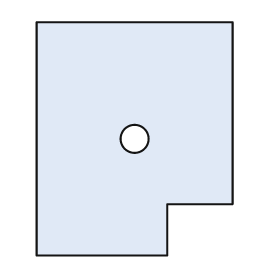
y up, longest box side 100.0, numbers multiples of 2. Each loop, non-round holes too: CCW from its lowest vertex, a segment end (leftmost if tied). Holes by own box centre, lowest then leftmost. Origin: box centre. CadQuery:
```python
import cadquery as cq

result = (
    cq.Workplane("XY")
    .moveTo(-42.0, -50.0)
    .lineTo(14.0, -50.0)
    .lineTo(14.0, -28.0)
    .lineTo(42.0, -28.0)
    .lineTo(42.0, 50.0)
    .lineTo(-42.0, 50.0)
    .close()
    .moveTo(0.0, 0.0)
    .circle(6.0)
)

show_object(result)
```